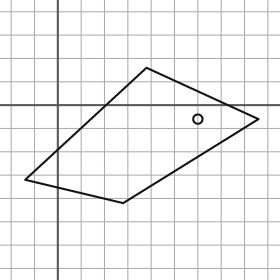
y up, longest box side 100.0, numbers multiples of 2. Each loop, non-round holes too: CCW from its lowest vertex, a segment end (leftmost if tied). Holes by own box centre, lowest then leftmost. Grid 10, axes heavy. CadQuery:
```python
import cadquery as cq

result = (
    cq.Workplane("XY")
    .moveTo(28.0, -42.0)
    .lineTo(86.0, -6.0)
    .lineTo(38.0, 16.0)
    .lineTo(-14.0, -32.0)
    .close()
    .moveTo(60.0, -6.0)
    .circle(2.0)
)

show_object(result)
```